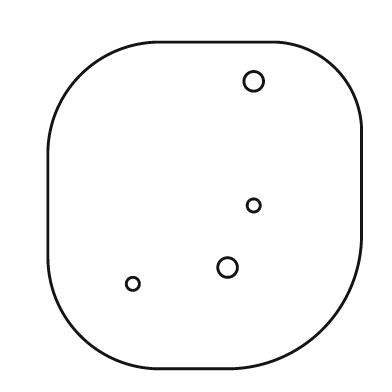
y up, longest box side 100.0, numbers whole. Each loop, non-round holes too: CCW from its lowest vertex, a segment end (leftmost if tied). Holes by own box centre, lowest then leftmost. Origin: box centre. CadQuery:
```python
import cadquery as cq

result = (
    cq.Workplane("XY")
    .moveTo(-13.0, -50.0)
    .lineTo(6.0, -50.0)
    .threePointArc((36.0, -38.0), (48.0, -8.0))
    .lineTo(48.0, 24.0)
    .threePointArc((40.0, 42.0), (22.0, 50.0))
    .lineTo(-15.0, 50.0)
    .threePointArc((-38.0, 40.0), (-48.0, 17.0))
    .lineTo(-48.0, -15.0)
    .threePointArc((-38.0, -40.0), (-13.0, -50.0))
    .close()
    .moveTo(-22.0, -24.0)
    .circle(2.0)
    .moveTo(7.0, -19.0)
    .circle(3.0)
    .moveTo(15.0, 0.0)
    .circle(2.0)
    .moveTo(15.0, 38.0)
    .circle(3.0)
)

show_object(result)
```